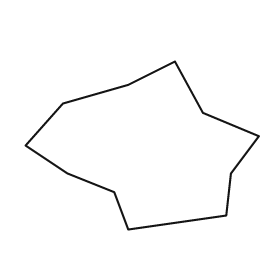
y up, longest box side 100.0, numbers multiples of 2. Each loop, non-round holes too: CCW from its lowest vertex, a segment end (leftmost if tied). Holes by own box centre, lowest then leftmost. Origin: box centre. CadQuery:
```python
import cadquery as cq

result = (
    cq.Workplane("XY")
    .moveTo(-6.0, -36.0)
    .lineTo(36.0, -30.0)
    .lineTo(38.0, -12.0)
    .lineTo(50.0, 4.0)
    .lineTo(26.0, 14.0)
    .lineTo(14.0, 36.0)
    .lineTo(-6.0, 26.0)
    .lineTo(-34.0, 18.0)
    .lineTo(-50.0, 0.0)
    .lineTo(-32.0, -12.0)
    .lineTo(-12.0, -20.0)
    .close()
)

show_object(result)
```